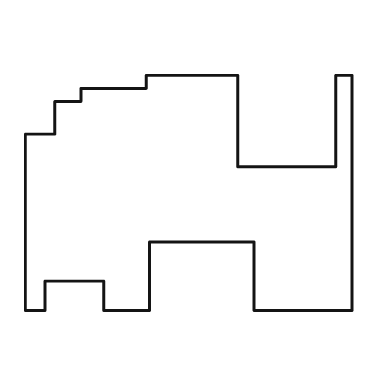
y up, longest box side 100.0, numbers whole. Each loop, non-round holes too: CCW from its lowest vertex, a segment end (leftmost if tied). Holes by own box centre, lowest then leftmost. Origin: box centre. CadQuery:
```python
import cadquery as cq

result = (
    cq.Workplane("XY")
    .moveTo(-50.0, -36.0)
    .lineTo(-44.0, -36.0)
    .lineTo(-44.0, -27.0)
    .lineTo(-26.0, -27.0)
    .lineTo(-26.0, -36.0)
    .lineTo(-12.0, -36.0)
    .lineTo(-12.0, -15.0)
    .lineTo(20.0, -15.0)
    .lineTo(20.0, -36.0)
    .lineTo(50.0, -36.0)
    .lineTo(50.0, 36.0)
    .lineTo(45.0, 36.0)
    .lineTo(45.0, 8.0)
    .lineTo(15.0, 8.0)
    .lineTo(15.0, 36.0)
    .lineTo(-13.0, 36.0)
    .lineTo(-13.0, 32.0)
    .lineTo(-33.0, 32.0)
    .lineTo(-33.0, 28.0)
    .lineTo(-41.0, 28.0)
    .lineTo(-41.0, 18.0)
    .lineTo(-50.0, 18.0)
    .close()
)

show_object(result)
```